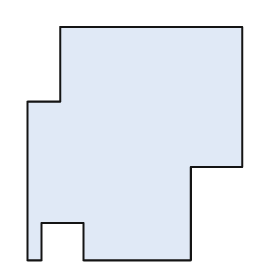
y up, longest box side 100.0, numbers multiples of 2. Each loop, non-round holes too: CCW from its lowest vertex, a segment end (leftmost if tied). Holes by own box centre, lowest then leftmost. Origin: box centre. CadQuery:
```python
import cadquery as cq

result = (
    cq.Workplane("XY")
    .moveTo(-46.0, -50.0)
    .lineTo(-40.0, -50.0)
    .lineTo(-40.0, -34.0)
    .lineTo(-22.0, -34.0)
    .lineTo(-22.0, -50.0)
    .lineTo(24.0, -50.0)
    .lineTo(24.0, -10.0)
    .lineTo(46.0, -10.0)
    .lineTo(46.0, 50.0)
    .lineTo(-32.0, 50.0)
    .lineTo(-32.0, 18.0)
    .lineTo(-46.0, 18.0)
    .close()
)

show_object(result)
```